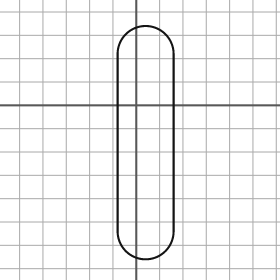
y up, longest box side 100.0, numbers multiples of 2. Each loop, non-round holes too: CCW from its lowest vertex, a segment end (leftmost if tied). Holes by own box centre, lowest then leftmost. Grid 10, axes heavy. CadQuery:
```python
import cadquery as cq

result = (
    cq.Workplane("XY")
    .moveTo(-8.0, -54.0)
    .threePointArc((4.0, -66.0), (16.0, -54.0))
    .lineTo(16.0, 22.0)
    .threePointArc((4.0, 34.0), (-8.0, 22.0))
    .close()
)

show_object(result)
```